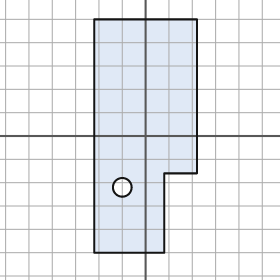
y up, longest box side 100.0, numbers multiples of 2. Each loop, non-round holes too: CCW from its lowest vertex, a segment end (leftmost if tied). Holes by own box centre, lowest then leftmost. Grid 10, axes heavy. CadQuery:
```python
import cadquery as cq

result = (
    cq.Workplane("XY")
    .moveTo(-22.0, -50.0)
    .lineTo(8.0, -50.0)
    .lineTo(8.0, -16.0)
    .lineTo(22.0, -16.0)
    .lineTo(22.0, 50.0)
    .lineTo(-22.0, 50.0)
    .close()
    .moveTo(-10.0, -22.0)
    .circle(4.0)
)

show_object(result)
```